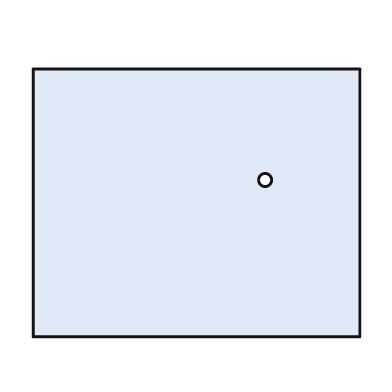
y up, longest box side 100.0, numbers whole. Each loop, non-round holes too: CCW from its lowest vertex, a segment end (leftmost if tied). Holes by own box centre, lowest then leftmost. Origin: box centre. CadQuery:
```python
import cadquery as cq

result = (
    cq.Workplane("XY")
    .moveTo(-50.0, -41.0)
    .lineTo(50.0, -41.0)
    .lineTo(50.0, 41.0)
    .lineTo(-50.0, 41.0)
    .close()
    .moveTo(21.0, 7.0)
    .circle(2.0)
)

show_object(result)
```